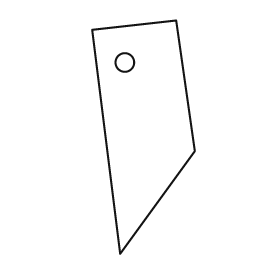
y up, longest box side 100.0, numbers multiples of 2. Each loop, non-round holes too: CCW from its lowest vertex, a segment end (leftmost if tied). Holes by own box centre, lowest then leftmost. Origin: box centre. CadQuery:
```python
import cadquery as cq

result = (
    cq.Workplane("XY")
    .moveTo(-10.0, -50.0)
    .lineTo(22.0, -6.0)
    .lineTo(14.0, 50.0)
    .lineTo(-22.0, 46.0)
    .close()
    .moveTo(-8.0, 32.0)
    .circle(4.0)
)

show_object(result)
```